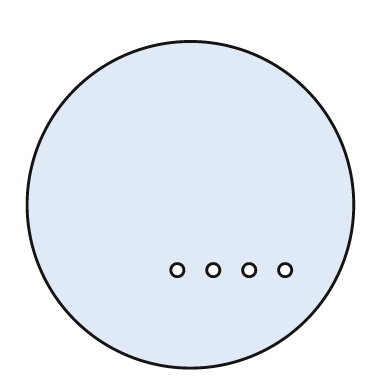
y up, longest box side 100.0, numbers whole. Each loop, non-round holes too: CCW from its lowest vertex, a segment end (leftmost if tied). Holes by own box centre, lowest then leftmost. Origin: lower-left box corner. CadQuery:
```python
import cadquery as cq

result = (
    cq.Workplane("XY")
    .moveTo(50.0, 50.0)
    .circle(50.0)
    .moveTo(46.0, 30.0)
    .circle(2.0)
    .moveTo(57.0, 30.0)
    .circle(2.0)
    .moveTo(68.0, 30.0)
    .circle(2.0)
    .moveTo(79.0, 30.0)
    .circle(2.0)
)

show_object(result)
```